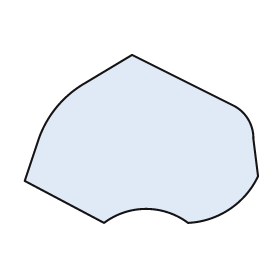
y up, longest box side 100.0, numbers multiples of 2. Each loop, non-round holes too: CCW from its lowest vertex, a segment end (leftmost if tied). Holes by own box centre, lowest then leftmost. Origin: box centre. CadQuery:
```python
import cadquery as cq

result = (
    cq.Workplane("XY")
    .moveTo(-16.0, -36.0)
    .threePointArc((2.0, -30.0), (20.0, -36.0))
    .threePointArc((38.0, -30.0), (50.0, -16.0))
    .lineTo(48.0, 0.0)
    .threePointArc((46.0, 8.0), (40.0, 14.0))
    .lineTo(-4.0, 36.0)
    .lineTo(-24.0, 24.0)
    .threePointArc((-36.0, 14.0), (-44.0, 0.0))
    .lineTo(-50.0, -18.0)
    .close()
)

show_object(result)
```